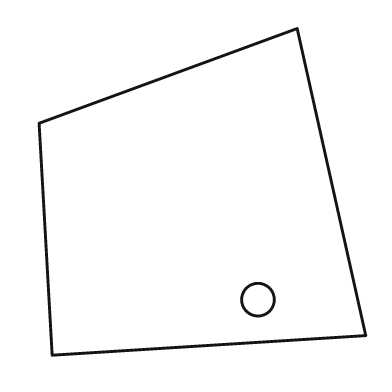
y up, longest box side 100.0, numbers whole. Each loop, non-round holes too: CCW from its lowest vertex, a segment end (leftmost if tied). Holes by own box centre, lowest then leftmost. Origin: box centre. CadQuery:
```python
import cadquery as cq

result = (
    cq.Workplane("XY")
    .moveTo(-46.0, -50.0)
    .lineTo(50.0, -44.0)
    .lineTo(29.0, 50.0)
    .lineTo(-50.0, 21.0)
    .close()
    .moveTo(17.0, -33.0)
    .circle(5.0)
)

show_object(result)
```